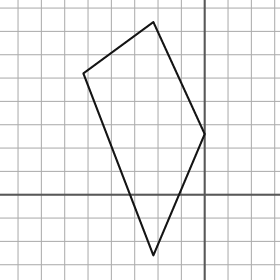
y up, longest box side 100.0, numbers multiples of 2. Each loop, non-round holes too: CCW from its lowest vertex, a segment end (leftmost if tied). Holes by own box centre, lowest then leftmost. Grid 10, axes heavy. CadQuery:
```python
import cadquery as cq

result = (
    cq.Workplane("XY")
    .moveTo(-22.0, -26.0)
    .lineTo(0.0, 26.0)
    .lineTo(-22.0, 74.0)
    .lineTo(-52.0, 52.0)
    .close()
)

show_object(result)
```